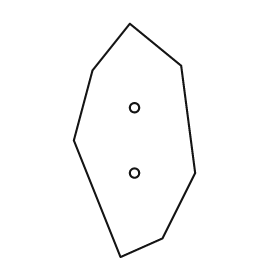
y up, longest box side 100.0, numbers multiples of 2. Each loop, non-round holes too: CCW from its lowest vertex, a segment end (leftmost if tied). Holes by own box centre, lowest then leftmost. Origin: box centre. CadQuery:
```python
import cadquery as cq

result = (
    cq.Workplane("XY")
    .moveTo(-6.0, -50.0)
    .lineTo(12.0, -42.0)
    .lineTo(26.0, -14.0)
    .lineTo(20.0, 32.0)
    .lineTo(-2.0, 50.0)
    .lineTo(-18.0, 30.0)
    .lineTo(-26.0, 0.0)
    .close()
    .moveTo(0.0, -14.0)
    .circle(2.0)
    .moveTo(0.0, 14.0)
    .circle(2.0)
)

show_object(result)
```